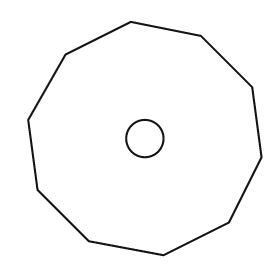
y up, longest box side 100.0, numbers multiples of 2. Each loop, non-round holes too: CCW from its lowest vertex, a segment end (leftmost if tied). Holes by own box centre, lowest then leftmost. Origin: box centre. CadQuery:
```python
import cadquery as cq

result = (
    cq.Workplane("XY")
    .moveTo(8.0, -50.0)
    .lineTo(36.0, -36.0)
    .lineTo(50.0, -8.0)
    .lineTo(46.0, 22.0)
    .lineTo(24.0, 44.0)
    .lineTo(-6.0, 50.0)
    .lineTo(-34.0, 36.0)
    .lineTo(-50.0, 8.0)
    .lineTo(-46.0, -22.0)
    .lineTo(-24.0, -44.0)
    .close()
    .moveTo(0.0, 0.0)
    .circle(8.0)
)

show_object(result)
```